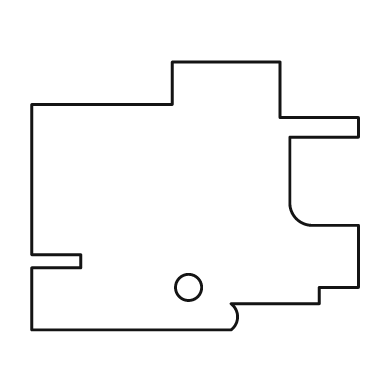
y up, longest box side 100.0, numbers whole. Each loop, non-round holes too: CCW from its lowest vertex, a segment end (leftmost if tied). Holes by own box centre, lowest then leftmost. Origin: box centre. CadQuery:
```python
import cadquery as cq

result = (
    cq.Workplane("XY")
    .moveTo(-50.0, -41.0)
    .lineTo(11.0, -41.0)
    .threePointArc((13.0, -37.0), (11.0, -33.0))
    .lineTo(38.0, -33.0)
    .lineTo(38.0, -28.0)
    .lineTo(50.0, -28.0)
    .lineTo(50.0, -9.0)
    .lineTo(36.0, -9.0)
    .threePointArc((31.0, -7.0), (29.0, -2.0))
    .lineTo(29.0, 18.0)
    .lineTo(50.0, 18.0)
    .lineTo(50.0, 24.0)
    .lineTo(26.0, 24.0)
    .lineTo(26.0, 41.0)
    .lineTo(-7.0, 41.0)
    .lineTo(-7.0, 28.0)
    .lineTo(-50.0, 28.0)
    .lineTo(-50.0, -18.0)
    .lineTo(-35.0, -18.0)
    .lineTo(-35.0, -22.0)
    .lineTo(-50.0, -22.0)
    .close()
    .moveTo(-2.0, -28.0)
    .circle(4.0)
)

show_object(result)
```